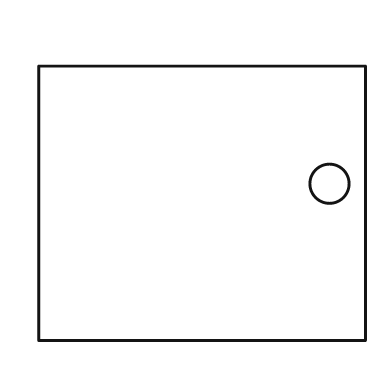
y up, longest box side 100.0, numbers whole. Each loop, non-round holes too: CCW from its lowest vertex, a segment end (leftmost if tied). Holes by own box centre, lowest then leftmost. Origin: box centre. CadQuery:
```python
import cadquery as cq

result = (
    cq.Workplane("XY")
    .moveTo(-50.0, -42.0)
    .lineTo(50.0, -42.0)
    .lineTo(50.0, 42.0)
    .lineTo(-50.0, 42.0)
    .close()
    .moveTo(39.0, 6.0)
    .circle(6.0)
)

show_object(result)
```